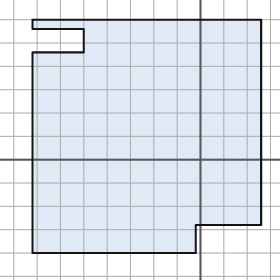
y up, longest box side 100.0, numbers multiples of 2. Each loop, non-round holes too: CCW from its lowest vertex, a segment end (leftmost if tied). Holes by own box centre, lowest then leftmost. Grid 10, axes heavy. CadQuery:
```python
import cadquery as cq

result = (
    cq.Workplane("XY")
    .moveTo(-72.0, -40.0)
    .lineTo(-2.0, -40.0)
    .lineTo(-2.0, -28.0)
    .lineTo(26.0, -28.0)
    .lineTo(26.0, 60.0)
    .lineTo(-72.0, 60.0)
    .lineTo(-72.0, 56.0)
    .lineTo(-50.0, 56.0)
    .lineTo(-50.0, 46.0)
    .lineTo(-72.0, 46.0)
    .close()
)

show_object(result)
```